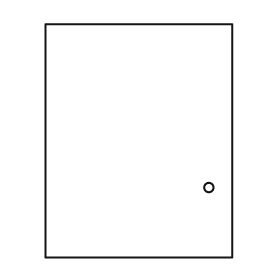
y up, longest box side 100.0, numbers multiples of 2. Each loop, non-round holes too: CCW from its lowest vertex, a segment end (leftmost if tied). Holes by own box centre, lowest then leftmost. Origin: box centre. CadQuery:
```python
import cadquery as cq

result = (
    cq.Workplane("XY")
    .moveTo(-40.0, -50.0)
    .lineTo(40.0, -50.0)
    .lineTo(40.0, 50.0)
    .lineTo(-40.0, 50.0)
    .close()
    .moveTo(30.0, -20.0)
    .circle(2.0)
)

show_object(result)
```